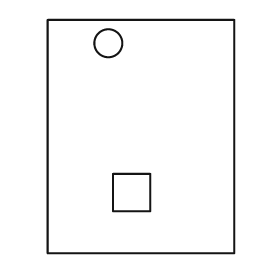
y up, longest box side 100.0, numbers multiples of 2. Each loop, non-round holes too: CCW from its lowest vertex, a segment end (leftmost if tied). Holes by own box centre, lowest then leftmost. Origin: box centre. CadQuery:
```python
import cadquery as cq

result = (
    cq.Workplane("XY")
    .moveTo(-40.0, -50.0)
    .lineTo(40.0, -50.0)
    .lineTo(40.0, 50.0)
    .lineTo(-40.0, 50.0)
    .close()
    .moveTo(-12.0, -32.0)
    .lineTo(4.0, -32.0)
    .lineTo(4.0, -16.0)
    .lineTo(-12.0, -16.0)
    .close()
    .moveTo(-14.0, 40.0)
    .circle(6.0)
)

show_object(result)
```